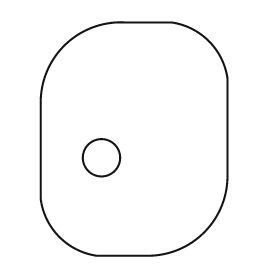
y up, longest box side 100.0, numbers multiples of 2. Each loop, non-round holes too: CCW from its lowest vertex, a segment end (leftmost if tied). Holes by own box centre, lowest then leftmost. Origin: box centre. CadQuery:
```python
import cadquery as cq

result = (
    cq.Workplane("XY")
    .moveTo(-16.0, -50.0)
    .lineTo(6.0, -50.0)
    .threePointArc((30.0, -40.0), (40.0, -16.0))
    .lineTo(40.0, 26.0)
    .threePointArc((32.0, 42.0), (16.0, 50.0))
    .lineTo(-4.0, 50.0)
    .threePointArc((-30.0, 40.0), (-40.0, 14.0))
    .lineTo(-40.0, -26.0)
    .threePointArc((-32.0, -42.0), (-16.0, -50.0))
    .close()
    .moveTo(-14.0, -8.0)
    .circle(8.0)
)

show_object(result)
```